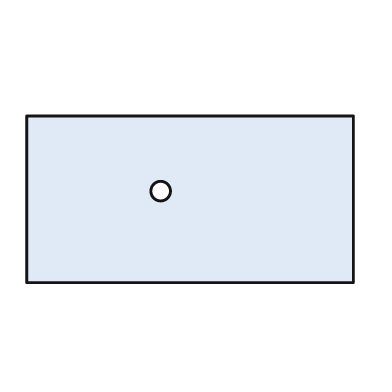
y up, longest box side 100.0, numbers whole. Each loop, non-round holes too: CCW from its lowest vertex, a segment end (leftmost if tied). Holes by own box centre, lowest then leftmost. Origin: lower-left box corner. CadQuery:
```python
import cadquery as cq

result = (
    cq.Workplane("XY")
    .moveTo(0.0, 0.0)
    .lineTo(100.0, 0.0)
    .lineTo(100.0, 51.0)
    .lineTo(0.0, 51.0)
    .close()
    .moveTo(41.0, 28.0)
    .circle(3.0)
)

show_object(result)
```